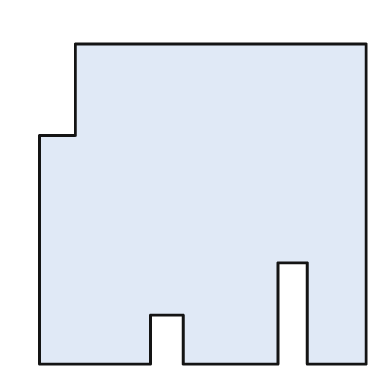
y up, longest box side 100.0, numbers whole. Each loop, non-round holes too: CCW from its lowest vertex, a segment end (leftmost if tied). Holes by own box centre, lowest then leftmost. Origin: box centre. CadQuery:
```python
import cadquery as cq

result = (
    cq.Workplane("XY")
    .moveTo(-50.0, -49.0)
    .lineTo(-16.0, -49.0)
    .lineTo(-16.0, -34.0)
    .lineTo(-6.0, -34.0)
    .lineTo(-6.0, -49.0)
    .lineTo(23.0, -49.0)
    .lineTo(23.0, -18.0)
    .lineTo(32.0, -18.0)
    .lineTo(32.0, -49.0)
    .lineTo(50.0, -49.0)
    .lineTo(50.0, 49.0)
    .lineTo(-39.0, 49.0)
    .lineTo(-39.0, 21.0)
    .lineTo(-50.0, 21.0)
    .close()
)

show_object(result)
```